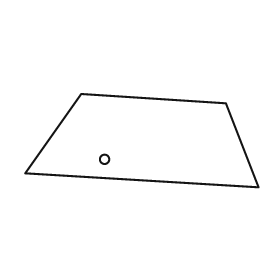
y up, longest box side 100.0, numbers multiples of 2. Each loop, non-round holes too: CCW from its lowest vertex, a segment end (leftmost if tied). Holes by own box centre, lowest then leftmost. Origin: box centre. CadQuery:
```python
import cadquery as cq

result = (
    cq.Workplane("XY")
    .moveTo(50.0, -20.0)
    .lineTo(36.0, 16.0)
    .lineTo(-26.0, 20.0)
    .lineTo(-50.0, -14.0)
    .close()
    .moveTo(-16.0, -8.0)
    .circle(2.0)
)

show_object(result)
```